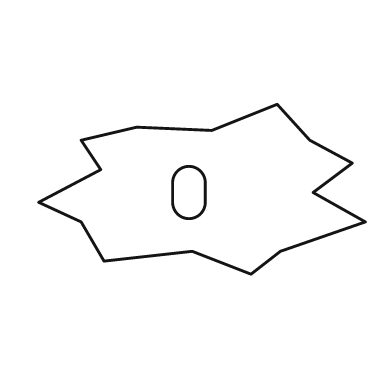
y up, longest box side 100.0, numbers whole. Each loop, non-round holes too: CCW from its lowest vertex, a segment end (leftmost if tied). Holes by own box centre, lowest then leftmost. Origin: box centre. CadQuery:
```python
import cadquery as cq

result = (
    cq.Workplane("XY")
    .moveTo(15.0, -26.0)
    .lineTo(24.0, -19.0)
    .lineTo(50.0, -10.0)
    .lineTo(34.0, -1.0)
    .lineTo(46.0, 8.0)
    .lineTo(33.0, 15.0)
    .lineTo(23.0, 26.0)
    .lineTo(3.0, 18.0)
    .lineTo(-20.0, 19.0)
    .lineTo(-37.0, 15.0)
    .lineTo(-31.0, 6.0)
    .lineTo(-50.0, -4.0)
    .lineTo(-37.0, -10.0)
    .lineTo(-30.0, -22.0)
    .lineTo(-3.0, -19.0)
    .close()
    .moveTo(-9.0, -4.0)
    .threePointArc((-4.0, -9.0), (1.0, -4.0))
    .lineTo(1.0, 2.0)
    .threePointArc((-4.0, 7.0), (-9.0, 2.0))
    .close()
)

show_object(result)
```